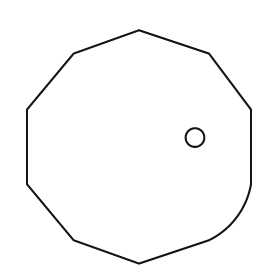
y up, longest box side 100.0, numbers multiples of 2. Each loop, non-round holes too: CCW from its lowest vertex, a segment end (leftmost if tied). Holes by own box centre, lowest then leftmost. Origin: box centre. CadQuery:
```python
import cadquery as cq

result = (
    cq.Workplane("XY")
    .moveTo(0.0, -50.0)
    .lineTo(30.0, -40.0)
    .threePointArc((42.0, -30.0), (48.0, -16.0))
    .lineTo(48.0, 16.0)
    .lineTo(30.0, 40.0)
    .lineTo(0.0, 50.0)
    .lineTo(-28.0, 40.0)
    .lineTo(-48.0, 16.0)
    .lineTo(-48.0, -16.0)
    .lineTo(-28.0, -40.0)
    .close()
    .moveTo(24.0, 4.0)
    .circle(4.0)
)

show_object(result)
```